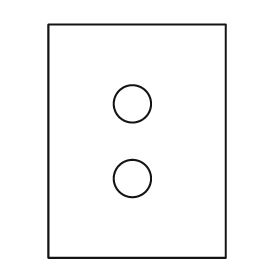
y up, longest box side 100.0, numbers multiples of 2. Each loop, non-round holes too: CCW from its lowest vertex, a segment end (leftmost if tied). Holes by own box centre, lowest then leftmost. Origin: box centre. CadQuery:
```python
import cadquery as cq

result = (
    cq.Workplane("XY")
    .moveTo(-38.0, -50.0)
    .lineTo(38.0, -50.0)
    .lineTo(38.0, 50.0)
    .lineTo(-38.0, 50.0)
    .close()
    .moveTo(-2.0, -16.0)
    .circle(8.0)
    .moveTo(-2.0, 16.0)
    .circle(8.0)
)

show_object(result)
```